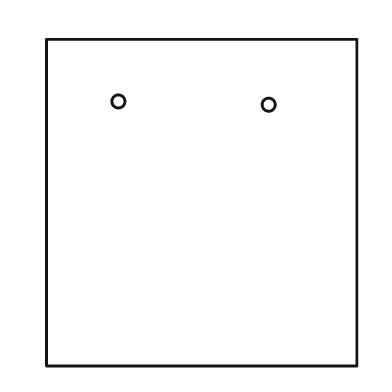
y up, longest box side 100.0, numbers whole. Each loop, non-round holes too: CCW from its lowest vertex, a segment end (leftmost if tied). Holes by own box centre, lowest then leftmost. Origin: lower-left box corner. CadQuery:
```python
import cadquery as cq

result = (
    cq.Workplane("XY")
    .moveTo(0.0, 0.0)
    .lineTo(95.0, 0.0)
    .lineTo(95.0, 100.0)
    .lineTo(0.0, 100.0)
    .close()
    .moveTo(68.0, 80.0)
    .circle(2.0)
    .moveTo(22.0, 81.0)
    .circle(2.0)
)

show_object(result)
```